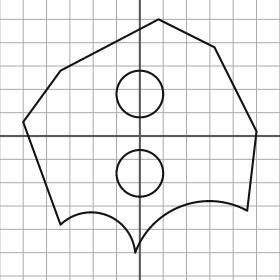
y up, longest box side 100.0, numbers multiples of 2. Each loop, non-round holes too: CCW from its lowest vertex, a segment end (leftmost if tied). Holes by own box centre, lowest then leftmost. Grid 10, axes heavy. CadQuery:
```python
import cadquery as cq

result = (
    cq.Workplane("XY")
    .moveTo(-2.0, -50.0)
    .threePointArc((18.0, -30.0), (46.0, -32.0))
    .lineTo(50.0, 2.0)
    .lineTo(32.0, 38.0)
    .lineTo(8.0, 50.0)
    .lineTo(-34.0, 28.0)
    .lineTo(-50.0, 6.0)
    .lineTo(-34.0, -38.0)
    .threePointArc((-14.0, -34.0), (-2.0, -50.0))
    .close()
    .moveTo(0.0, -16.0)
    .circle(10.0)
    .moveTo(0.0, 18.0)
    .circle(10.0)
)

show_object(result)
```